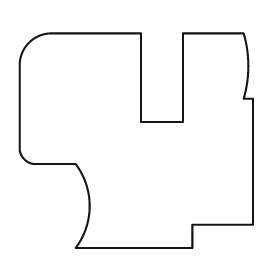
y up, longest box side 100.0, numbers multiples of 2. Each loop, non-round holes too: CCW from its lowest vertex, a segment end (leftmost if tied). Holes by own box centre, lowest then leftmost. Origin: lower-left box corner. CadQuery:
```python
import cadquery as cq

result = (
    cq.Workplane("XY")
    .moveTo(24.0, 0.0)
    .lineTo(74.0, 0.0)
    .lineTo(74.0, 10.0)
    .lineTo(100.0, 10.0)
    .lineTo(100.0, 64.0)
    .lineTo(96.0, 64.0)
    .threePointArc((98.0, 78.0), (96.0, 92.0))
    .lineTo(70.0, 92.0)
    .lineTo(70.0, 54.0)
    .lineTo(52.0, 54.0)
    .lineTo(52.0, 92.0)
    .lineTo(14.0, 92.0)
    .threePointArc((4.0, 88.0), (0.0, 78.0))
    .lineTo(0.0, 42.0)
    .threePointArc((2.0, 38.0), (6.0, 36.0))
    .lineTo(24.0, 36.0)
    .threePointArc((30.0, 18.0), (24.0, 0.0))
    .close()
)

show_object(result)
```